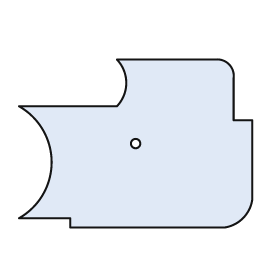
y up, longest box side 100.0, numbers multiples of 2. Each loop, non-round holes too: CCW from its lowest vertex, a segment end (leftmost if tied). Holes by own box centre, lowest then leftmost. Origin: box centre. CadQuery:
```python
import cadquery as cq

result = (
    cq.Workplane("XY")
    .moveTo(-28.0, -36.0)
    .lineTo(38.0, -36.0)
    .threePointArc((46.0, -32.0), (50.0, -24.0))
    .lineTo(50.0, 10.0)
    .lineTo(42.0, 10.0)
    .lineTo(42.0, 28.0)
    .threePointArc((40.0, 34.0), (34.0, 36.0))
    .lineTo(-8.0, 36.0)
    .threePointArc((-4.0, 26.0), (-8.0, 16.0))
    .lineTo(-50.0, 16.0)
    .threePointArc((-36.0, -8.0), (-50.0, -32.0))
    .lineTo(-28.0, -32.0)
    .close()
    .moveTo(0.0, 0.0)
    .circle(2.0)
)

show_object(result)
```